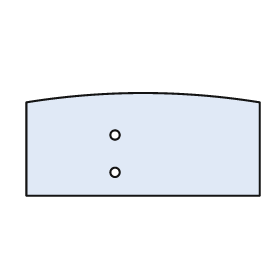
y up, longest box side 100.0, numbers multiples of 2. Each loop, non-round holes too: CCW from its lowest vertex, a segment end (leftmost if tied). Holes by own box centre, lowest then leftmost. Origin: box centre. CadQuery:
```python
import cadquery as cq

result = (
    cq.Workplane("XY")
    .moveTo(-50.0, -22.0)
    .lineTo(50.0, -22.0)
    .lineTo(50.0, 18.0)
    .threePointArc((0.0, 22.0), (-50.0, 18.0))
    .close()
    .moveTo(-12.0, -12.0)
    .circle(2.0)
    .moveTo(-12.0, 4.0)
    .circle(2.0)
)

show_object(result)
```